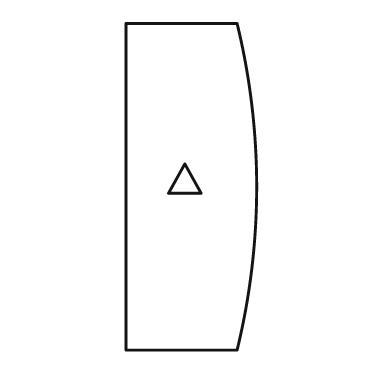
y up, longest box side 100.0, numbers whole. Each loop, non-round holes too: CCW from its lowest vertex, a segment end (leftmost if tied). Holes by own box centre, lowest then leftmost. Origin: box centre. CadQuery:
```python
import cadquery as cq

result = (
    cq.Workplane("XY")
    .moveTo(-20.0, -50.0)
    .lineTo(14.0, -50.0)
    .threePointArc((20.0, 0.0), (14.0, 50.0))
    .lineTo(-20.0, 50.0)
    .close()
    .moveTo(-7.0, -2.0)
    .lineTo(3.0, -2.0)
    .lineTo(-2.0, 7.0)
    .close()
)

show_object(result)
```